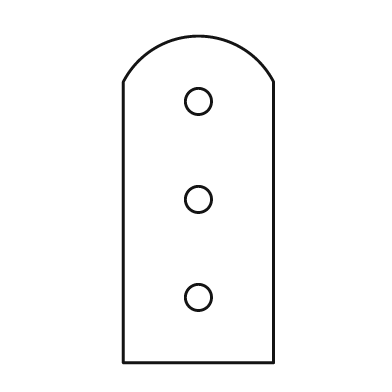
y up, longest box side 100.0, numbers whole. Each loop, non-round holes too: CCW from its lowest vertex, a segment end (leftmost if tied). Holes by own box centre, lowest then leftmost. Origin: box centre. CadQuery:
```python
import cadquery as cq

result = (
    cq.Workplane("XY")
    .moveTo(-23.0, -50.0)
    .lineTo(23.0, -50.0)
    .lineTo(23.0, 36.0)
    .threePointArc((0.0, 50.0), (-23.0, 36.0))
    .close()
    .moveTo(0.0, -30.0)
    .circle(4.0)
    .moveTo(0.0, 0.0)
    .circle(4.0)
    .moveTo(0.0, 30.0)
    .circle(4.0)
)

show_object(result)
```